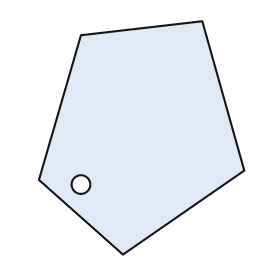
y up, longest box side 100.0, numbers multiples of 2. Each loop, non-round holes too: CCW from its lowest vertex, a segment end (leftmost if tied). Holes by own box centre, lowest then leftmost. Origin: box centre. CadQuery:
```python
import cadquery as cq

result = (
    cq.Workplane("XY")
    .moveTo(-8.0, -50.0)
    .lineTo(44.0, -14.0)
    .lineTo(26.0, 50.0)
    .lineTo(-26.0, 44.0)
    .lineTo(-44.0, -18.0)
    .close()
    .moveTo(-26.0, -20.0)
    .circle(4.0)
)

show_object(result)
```